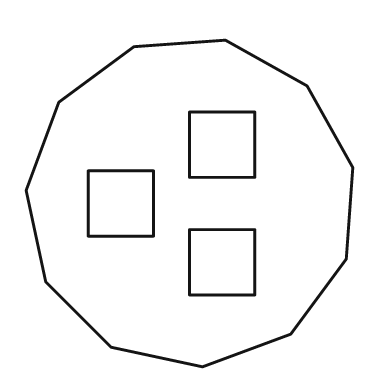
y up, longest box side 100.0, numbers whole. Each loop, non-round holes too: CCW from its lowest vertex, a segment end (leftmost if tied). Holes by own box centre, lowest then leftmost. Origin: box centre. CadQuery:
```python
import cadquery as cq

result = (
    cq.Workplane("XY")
    .moveTo(4.0, -50.0)
    .lineTo(31.0, -40.0)
    .lineTo(48.0, -17.0)
    .lineTo(50.0, 11.0)
    .lineTo(36.0, 36.0)
    .lineTo(11.0, 50.0)
    .lineTo(-17.0, 48.0)
    .lineTo(-40.0, 31.0)
    .lineTo(-50.0, 4.0)
    .lineTo(-44.0, -24.0)
    .lineTo(-24.0, -44.0)
    .close()
    .moveTo(0.0, -28.0)
    .lineTo(20.0, -28.0)
    .lineTo(20.0, -8.0)
    .lineTo(0.0, -8.0)
    .close()
    .moveTo(-31.0, -10.0)
    .lineTo(-11.0, -10.0)
    .lineTo(-11.0, 10.0)
    .lineTo(-31.0, 10.0)
    .close()
    .moveTo(0.0, 8.0)
    .lineTo(20.0, 8.0)
    .lineTo(20.0, 28.0)
    .lineTo(0.0, 28.0)
    .close()
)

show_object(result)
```